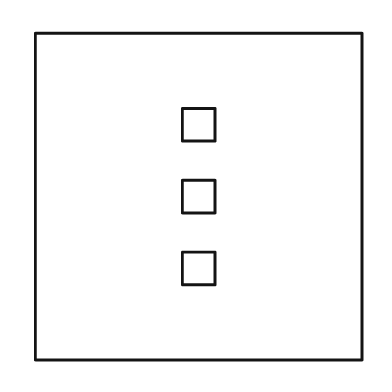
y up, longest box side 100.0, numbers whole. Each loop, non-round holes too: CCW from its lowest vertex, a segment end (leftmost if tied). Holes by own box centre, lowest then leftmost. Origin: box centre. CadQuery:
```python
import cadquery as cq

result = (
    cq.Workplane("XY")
    .moveTo(-50.0, -50.0)
    .lineTo(50.0, -50.0)
    .lineTo(50.0, 50.0)
    .lineTo(-50.0, 50.0)
    .close()
    .moveTo(-5.0, -27.0)
    .lineTo(5.0, -27.0)
    .lineTo(5.0, -17.0)
    .lineTo(-5.0, -17.0)
    .close()
    .moveTo(-5.0, -5.0)
    .lineTo(5.0, -5.0)
    .lineTo(5.0, 5.0)
    .lineTo(-5.0, 5.0)
    .close()
    .moveTo(-5.0, 17.0)
    .lineTo(5.0, 17.0)
    .lineTo(5.0, 27.0)
    .lineTo(-5.0, 27.0)
    .close()
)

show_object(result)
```